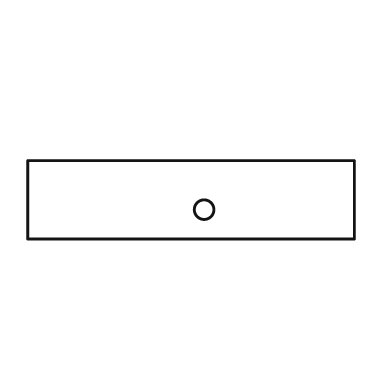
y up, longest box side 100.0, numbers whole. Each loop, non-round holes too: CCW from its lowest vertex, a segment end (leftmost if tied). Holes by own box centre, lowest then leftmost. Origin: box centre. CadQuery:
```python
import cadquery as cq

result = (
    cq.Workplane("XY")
    .moveTo(-50.0, -12.0)
    .lineTo(50.0, -12.0)
    .lineTo(50.0, 12.0)
    .lineTo(-50.0, 12.0)
    .close()
    .moveTo(4.0, -3.0)
    .circle(3.0)
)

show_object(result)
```